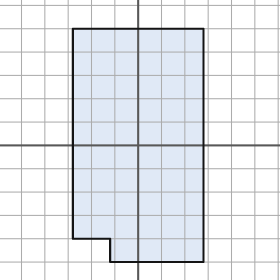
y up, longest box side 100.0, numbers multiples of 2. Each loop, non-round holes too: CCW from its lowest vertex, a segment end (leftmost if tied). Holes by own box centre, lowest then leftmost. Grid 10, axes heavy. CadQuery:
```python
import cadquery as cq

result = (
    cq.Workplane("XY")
    .moveTo(-12.0, -50.0)
    .lineTo(28.0, -50.0)
    .lineTo(28.0, 50.0)
    .lineTo(-28.0, 50.0)
    .lineTo(-28.0, -40.0)
    .lineTo(-12.0, -40.0)
    .close()
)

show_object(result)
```